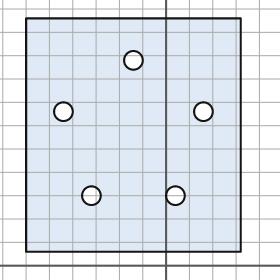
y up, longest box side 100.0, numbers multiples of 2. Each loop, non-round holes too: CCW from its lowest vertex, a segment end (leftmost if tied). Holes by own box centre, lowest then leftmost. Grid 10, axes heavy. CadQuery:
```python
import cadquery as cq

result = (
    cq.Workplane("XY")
    .moveTo(-60.0, 6.0)
    .lineTo(32.0, 6.0)
    .lineTo(32.0, 106.0)
    .lineTo(-60.0, 106.0)
    .close()
    .moveTo(-32.0, 30.0)
    .circle(4.0)
    .moveTo(4.0, 30.0)
    .circle(4.0)
    .moveTo(-44.0, 66.0)
    .circle(4.0)
    .moveTo(16.0, 66.0)
    .circle(4.0)
    .moveTo(-14.0, 88.0)
    .circle(4.0)
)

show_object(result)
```